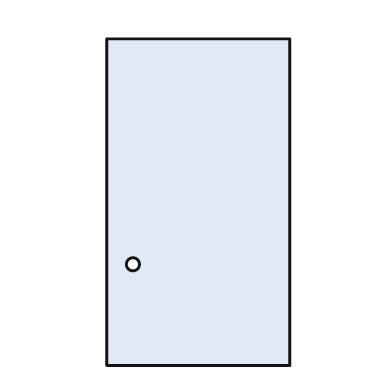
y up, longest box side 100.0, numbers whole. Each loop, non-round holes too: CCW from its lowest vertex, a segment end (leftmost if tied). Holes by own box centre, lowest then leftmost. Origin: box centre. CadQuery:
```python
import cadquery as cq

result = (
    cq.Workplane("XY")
    .moveTo(-28.0, -50.0)
    .lineTo(28.0, -50.0)
    .lineTo(28.0, 50.0)
    .lineTo(-28.0, 50.0)
    .close()
    .moveTo(-20.0, -19.0)
    .circle(2.0)
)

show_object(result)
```